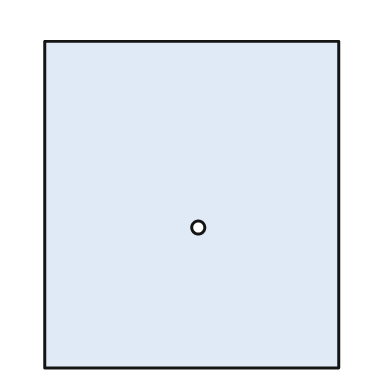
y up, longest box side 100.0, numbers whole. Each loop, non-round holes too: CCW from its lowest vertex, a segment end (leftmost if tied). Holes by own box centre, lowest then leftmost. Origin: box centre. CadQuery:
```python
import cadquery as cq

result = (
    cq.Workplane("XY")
    .moveTo(-45.0, -50.0)
    .lineTo(45.0, -50.0)
    .lineTo(45.0, 50.0)
    .lineTo(-45.0, 50.0)
    .close()
    .moveTo(2.0, -7.0)
    .circle(2.0)
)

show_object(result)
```